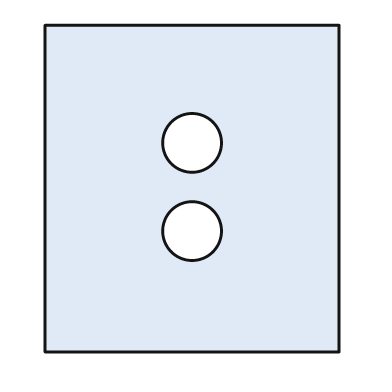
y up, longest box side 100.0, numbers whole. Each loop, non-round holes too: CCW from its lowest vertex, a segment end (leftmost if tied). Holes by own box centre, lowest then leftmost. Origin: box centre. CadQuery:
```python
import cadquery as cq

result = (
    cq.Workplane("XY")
    .moveTo(-45.0, -50.0)
    .lineTo(45.0, -50.0)
    .lineTo(45.0, 50.0)
    .lineTo(-45.0, 50.0)
    .close()
    .moveTo(0.0, -13.0)
    .circle(9.0)
    .moveTo(0.0, 14.0)
    .circle(9.0)
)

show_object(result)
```